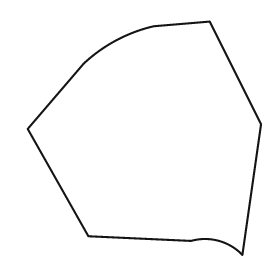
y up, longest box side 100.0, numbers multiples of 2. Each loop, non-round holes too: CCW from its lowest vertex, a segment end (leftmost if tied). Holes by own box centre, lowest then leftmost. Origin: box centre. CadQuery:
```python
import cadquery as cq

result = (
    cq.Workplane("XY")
    .moveTo(42.0, -50.0)
    .lineTo(50.0, 6.0)
    .lineTo(28.0, 50.0)
    .lineTo(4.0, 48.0)
    .threePointArc((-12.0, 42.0), (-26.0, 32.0))
    .lineTo(-50.0, 4.0)
    .lineTo(-24.0, -42.0)
    .lineTo(20.0, -44.0)
    .threePointArc((32.0, -44.0), (42.0, -50.0))
    .close()
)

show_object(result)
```